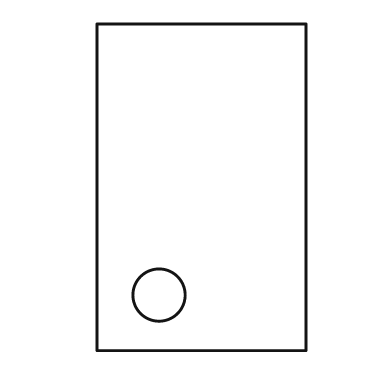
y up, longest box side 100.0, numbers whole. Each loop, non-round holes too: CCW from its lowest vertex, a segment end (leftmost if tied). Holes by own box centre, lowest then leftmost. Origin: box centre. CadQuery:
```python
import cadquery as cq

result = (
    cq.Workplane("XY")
    .moveTo(-32.0, -50.0)
    .lineTo(32.0, -50.0)
    .lineTo(32.0, 50.0)
    .lineTo(-32.0, 50.0)
    .close()
    .moveTo(-13.0, -33.0)
    .circle(8.0)
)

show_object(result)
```